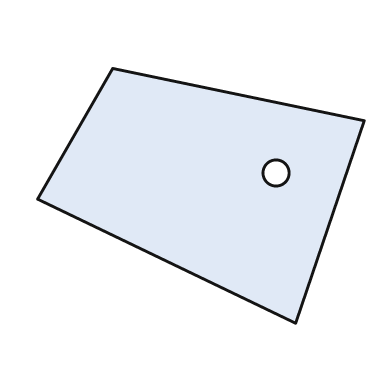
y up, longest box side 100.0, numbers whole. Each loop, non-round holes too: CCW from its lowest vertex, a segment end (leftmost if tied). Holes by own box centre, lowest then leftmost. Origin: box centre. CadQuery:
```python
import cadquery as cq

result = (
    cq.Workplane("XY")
    .moveTo(29.0, -39.0)
    .lineTo(50.0, 23.0)
    .lineTo(-27.0, 39.0)
    .lineTo(-50.0, -1.0)
    .close()
    .moveTo(23.0, 7.0)
    .circle(4.0)
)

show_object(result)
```